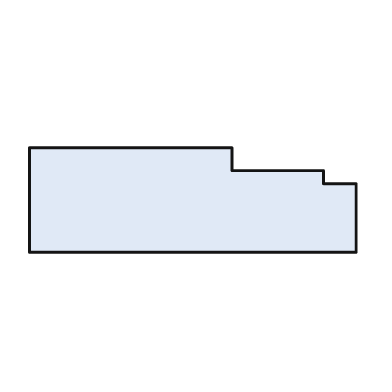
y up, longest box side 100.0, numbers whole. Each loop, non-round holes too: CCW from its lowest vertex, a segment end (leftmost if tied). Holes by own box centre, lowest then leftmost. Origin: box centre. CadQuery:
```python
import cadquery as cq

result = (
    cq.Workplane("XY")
    .moveTo(-50.0, -16.0)
    .lineTo(50.0, -16.0)
    .lineTo(50.0, 5.0)
    .lineTo(40.0, 5.0)
    .lineTo(40.0, 9.0)
    .lineTo(12.0, 9.0)
    .lineTo(12.0, 16.0)
    .lineTo(-50.0, 16.0)
    .close()
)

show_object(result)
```